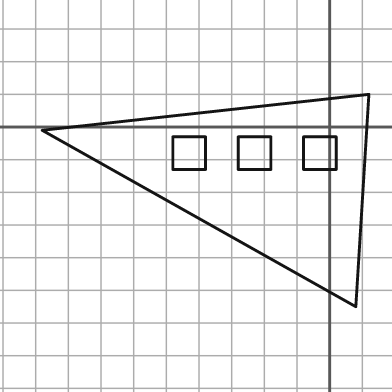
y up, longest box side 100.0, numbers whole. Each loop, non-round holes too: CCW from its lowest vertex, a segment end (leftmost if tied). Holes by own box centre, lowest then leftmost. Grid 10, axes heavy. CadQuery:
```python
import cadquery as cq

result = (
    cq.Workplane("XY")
    .moveTo(8.0, -55.0)
    .lineTo(12.0, 10.0)
    .lineTo(-88.0, -1.0)
    .close()
    .moveTo(-48.0, -13.0)
    .lineTo(-38.0, -13.0)
    .lineTo(-38.0, -3.0)
    .lineTo(-48.0, -3.0)
    .close()
    .moveTo(-28.0, -13.0)
    .lineTo(-18.0, -13.0)
    .lineTo(-18.0, -3.0)
    .lineTo(-28.0, -3.0)
    .close()
    .moveTo(-8.0, -13.0)
    .lineTo(2.0, -13.0)
    .lineTo(2.0, -3.0)
    .lineTo(-8.0, -3.0)
    .close()
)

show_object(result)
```